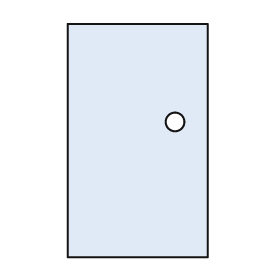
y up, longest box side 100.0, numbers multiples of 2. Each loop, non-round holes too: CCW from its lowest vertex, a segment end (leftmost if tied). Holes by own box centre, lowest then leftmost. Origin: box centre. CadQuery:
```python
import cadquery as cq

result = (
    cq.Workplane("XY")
    .moveTo(-30.0, -50.0)
    .lineTo(30.0, -50.0)
    .lineTo(30.0, 50.0)
    .lineTo(-30.0, 50.0)
    .close()
    .moveTo(16.0, 8.0)
    .circle(4.0)
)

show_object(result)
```